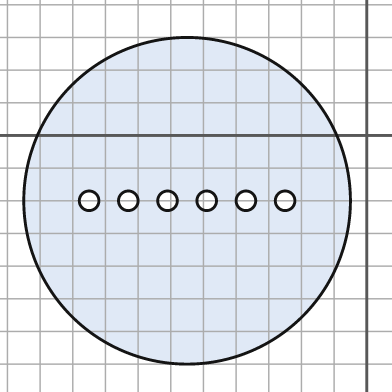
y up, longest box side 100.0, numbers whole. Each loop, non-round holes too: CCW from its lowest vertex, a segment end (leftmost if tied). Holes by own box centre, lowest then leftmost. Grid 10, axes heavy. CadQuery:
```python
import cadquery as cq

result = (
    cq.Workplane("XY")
    .moveTo(-55.0, -20.0)
    .circle(50.0)
    .moveTo(-85.0, -20.0)
    .circle(3.0)
    .moveTo(-73.0, -20.0)
    .circle(3.0)
    .moveTo(-61.0, -20.0)
    .circle(3.0)
    .moveTo(-49.0, -20.0)
    .circle(3.0)
    .moveTo(-37.0, -20.0)
    .circle(3.0)
    .moveTo(-25.0, -20.0)
    .circle(3.0)
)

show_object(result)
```